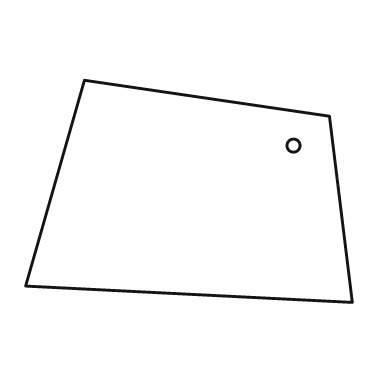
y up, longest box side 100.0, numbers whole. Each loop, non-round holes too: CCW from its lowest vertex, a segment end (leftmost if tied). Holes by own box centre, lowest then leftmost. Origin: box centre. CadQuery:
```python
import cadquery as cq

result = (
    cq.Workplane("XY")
    .moveTo(50.0, -34.0)
    .lineTo(43.0, 23.0)
    .lineTo(-32.0, 34.0)
    .lineTo(-50.0, -29.0)
    .close()
    .moveTo(32.0, 14.0)
    .circle(2.0)
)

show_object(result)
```